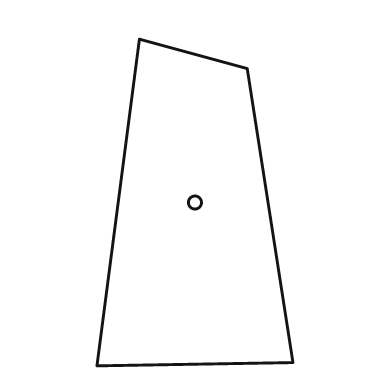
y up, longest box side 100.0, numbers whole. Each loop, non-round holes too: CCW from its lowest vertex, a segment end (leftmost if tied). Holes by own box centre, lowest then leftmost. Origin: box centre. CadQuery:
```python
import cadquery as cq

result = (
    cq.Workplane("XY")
    .moveTo(-30.0, -50.0)
    .lineTo(30.0, -49.0)
    .lineTo(16.0, 41.0)
    .lineTo(-17.0, 50.0)
    .close()
    .moveTo(0.0, 0.0)
    .circle(2.0)
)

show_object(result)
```